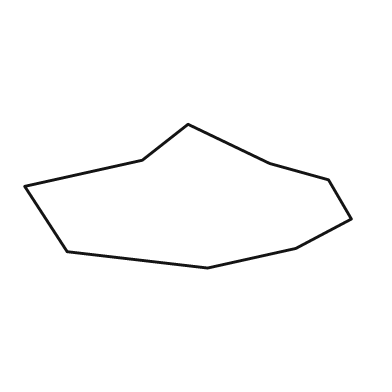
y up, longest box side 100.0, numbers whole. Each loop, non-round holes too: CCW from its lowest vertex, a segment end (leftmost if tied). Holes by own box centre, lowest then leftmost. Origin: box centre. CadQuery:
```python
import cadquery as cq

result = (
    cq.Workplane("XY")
    .moveTo(6.0, -22.0)
    .lineTo(33.0, -16.0)
    .lineTo(50.0, -7.0)
    .lineTo(43.0, 5.0)
    .lineTo(25.0, 10.0)
    .lineTo(0.0, 22.0)
    .lineTo(-14.0, 11.0)
    .lineTo(-50.0, 3.0)
    .lineTo(-37.0, -17.0)
    .close()
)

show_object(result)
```